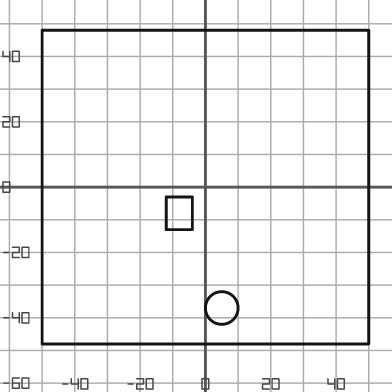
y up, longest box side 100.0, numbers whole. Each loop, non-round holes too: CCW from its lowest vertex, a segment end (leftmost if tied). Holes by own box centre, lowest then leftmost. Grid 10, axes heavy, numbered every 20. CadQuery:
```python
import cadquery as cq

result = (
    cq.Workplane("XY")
    .moveTo(-50.0, -48.0)
    .lineTo(50.0, -48.0)
    .lineTo(50.0, 48.0)
    .lineTo(-50.0, 48.0)
    .close()
    .moveTo(5.0, -37.0)
    .circle(5.0)
    .moveTo(-12.0, -13.0)
    .lineTo(-4.0, -13.0)
    .lineTo(-4.0, -3.0)
    .lineTo(-12.0, -3.0)
    .close()
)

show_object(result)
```